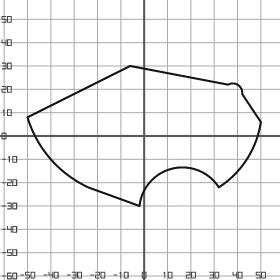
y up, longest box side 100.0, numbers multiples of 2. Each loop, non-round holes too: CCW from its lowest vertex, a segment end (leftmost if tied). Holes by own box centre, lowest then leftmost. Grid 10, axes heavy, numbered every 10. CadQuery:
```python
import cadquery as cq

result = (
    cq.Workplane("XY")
    .moveTo(-2.0, -30.0)
    .threePointArc((12.0, -14.0), (32.0, -22.0))
    .threePointArc((44.0, -10.0), (50.0, 6.0))
    .lineTo(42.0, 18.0)
    .threePointArc((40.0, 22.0), (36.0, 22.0))
    .lineTo(-6.0, 30.0)
    .lineTo(-50.0, 8.0)
    .threePointArc((-40.0, -10.0), (-24.0, -22.0))
    .close()
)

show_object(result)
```